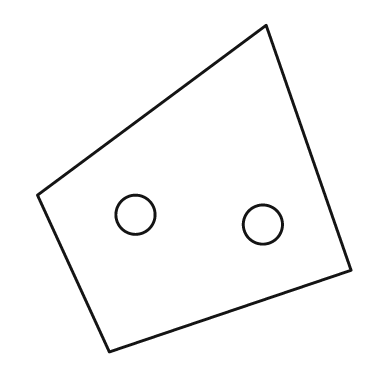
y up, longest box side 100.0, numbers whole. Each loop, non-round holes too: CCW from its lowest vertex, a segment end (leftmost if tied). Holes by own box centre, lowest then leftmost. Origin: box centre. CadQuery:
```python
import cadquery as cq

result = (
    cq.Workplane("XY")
    .moveTo(-26.0, -50.0)
    .lineTo(48.0, -25.0)
    .lineTo(22.0, 50.0)
    .lineTo(-48.0, -2.0)
    .close()
    .moveTo(21.0, -11.0)
    .circle(6.0)
    .moveTo(-18.0, -8.0)
    .circle(6.0)
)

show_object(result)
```